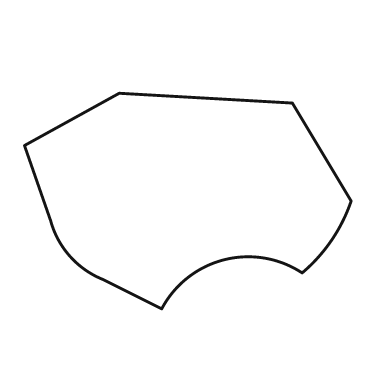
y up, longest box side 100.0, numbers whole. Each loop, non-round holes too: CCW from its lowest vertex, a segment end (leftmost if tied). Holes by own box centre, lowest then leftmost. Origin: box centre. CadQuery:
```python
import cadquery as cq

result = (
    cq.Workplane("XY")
    .moveTo(-8.0, -33.0)
    .threePointArc((11.0, -18.0), (35.0, -22.0))
    .threePointArc((44.0, -12.0), (50.0, 0.0))
    .lineTo(32.0, 30.0)
    .lineTo(-21.0, 33.0)
    .lineTo(-50.0, 17.0)
    .lineTo(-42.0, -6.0)
    .threePointArc((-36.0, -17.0), (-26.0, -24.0))
    .close()
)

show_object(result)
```